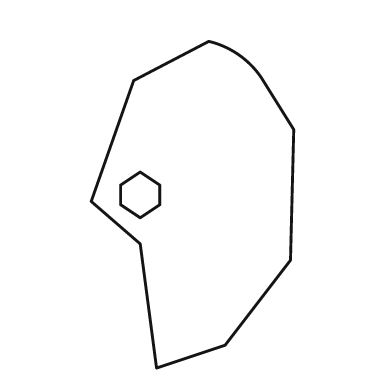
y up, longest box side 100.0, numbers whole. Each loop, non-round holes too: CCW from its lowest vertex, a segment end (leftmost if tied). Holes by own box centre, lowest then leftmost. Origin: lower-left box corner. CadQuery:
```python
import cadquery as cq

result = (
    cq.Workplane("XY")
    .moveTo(20.0, 0.0)
    .lineTo(41.0, 7.0)
    .lineTo(61.0, 33.0)
    .lineTo(62.0, 73.0)
    .lineTo(52.0, 89.0)
    .threePointArc((45.0, 96.0), (36.0, 100.0))
    .lineTo(13.0, 88.0)
    .lineTo(0.0, 51.0)
    .lineTo(15.0, 38.0)
    .close()
    .moveTo(15.0, 46.0)
    .lineTo(21.0, 50.0)
    .lineTo(21.0, 56.0)
    .lineTo(15.0, 60.0)
    .lineTo(9.0, 56.0)
    .lineTo(9.0, 50.0)
    .close()
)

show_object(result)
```